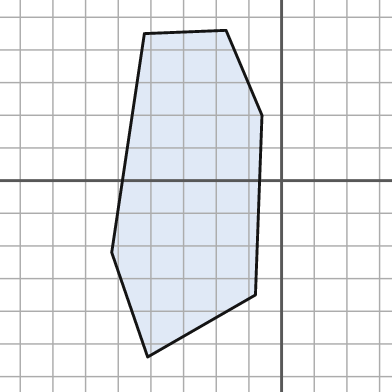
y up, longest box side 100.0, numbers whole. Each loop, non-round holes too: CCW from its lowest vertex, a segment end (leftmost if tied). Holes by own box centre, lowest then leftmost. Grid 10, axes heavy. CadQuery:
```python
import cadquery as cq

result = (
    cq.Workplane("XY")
    .moveTo(-41.0, -54.0)
    .lineTo(-8.0, -35.0)
    .lineTo(-6.0, 20.0)
    .lineTo(-17.0, 46.0)
    .lineTo(-42.0, 45.0)
    .lineTo(-52.0, -22.0)
    .close()
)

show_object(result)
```